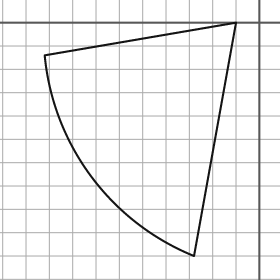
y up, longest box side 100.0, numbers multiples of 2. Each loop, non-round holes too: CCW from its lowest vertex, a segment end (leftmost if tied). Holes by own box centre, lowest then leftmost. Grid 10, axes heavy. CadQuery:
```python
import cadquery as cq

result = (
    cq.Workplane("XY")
    .moveTo(-28.0, -100.0)
    .lineTo(-10.0, 0.0)
    .lineTo(-92.0, -14.0)
    .threePointArc((-72.0, -66.0), (-28.0, -100.0))
    .close()
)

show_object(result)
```